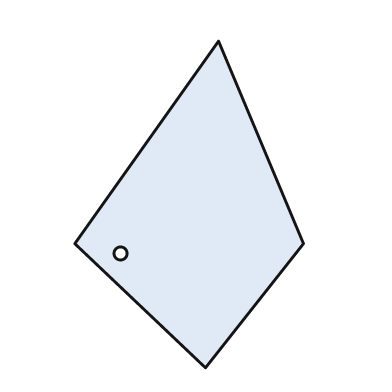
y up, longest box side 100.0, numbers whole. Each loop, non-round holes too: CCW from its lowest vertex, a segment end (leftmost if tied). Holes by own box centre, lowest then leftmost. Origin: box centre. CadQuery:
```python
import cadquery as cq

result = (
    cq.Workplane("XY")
    .moveTo(5.0, -50.0)
    .lineTo(35.0, -12.0)
    .lineTo(9.0, 50.0)
    .lineTo(-35.0, -12.0)
    .close()
    .moveTo(-21.0, -15.0)
    .circle(2.0)
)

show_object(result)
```